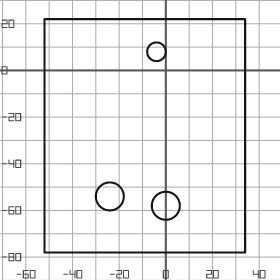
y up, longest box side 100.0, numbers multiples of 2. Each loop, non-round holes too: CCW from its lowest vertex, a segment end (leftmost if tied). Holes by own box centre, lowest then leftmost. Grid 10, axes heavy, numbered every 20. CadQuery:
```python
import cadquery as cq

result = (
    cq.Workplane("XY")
    .moveTo(-52.0, -78.0)
    .lineTo(34.0, -78.0)
    .lineTo(34.0, 22.0)
    .lineTo(-52.0, 22.0)
    .close()
    .moveTo(0.0, -58.0)
    .circle(6.0)
    .moveTo(-24.0, -54.0)
    .circle(6.0)
    .moveTo(-4.0, 8.0)
    .circle(4.0)
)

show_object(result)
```